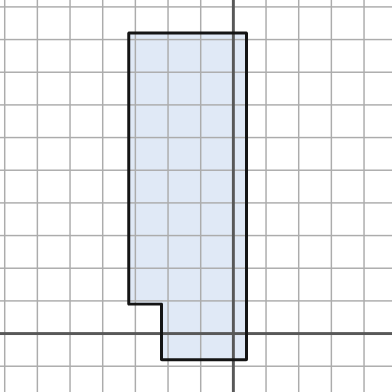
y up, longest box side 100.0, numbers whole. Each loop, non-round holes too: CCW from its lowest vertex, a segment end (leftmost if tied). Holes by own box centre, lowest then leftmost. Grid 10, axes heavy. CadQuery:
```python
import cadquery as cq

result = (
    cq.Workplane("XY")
    .moveTo(-22.0, -8.0)
    .lineTo(4.0, -8.0)
    .lineTo(4.0, 92.0)
    .lineTo(-32.0, 92.0)
    .lineTo(-32.0, 9.0)
    .lineTo(-22.0, 9.0)
    .close()
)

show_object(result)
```